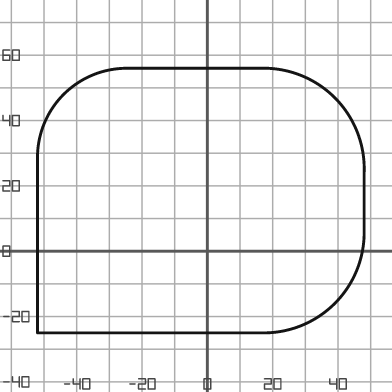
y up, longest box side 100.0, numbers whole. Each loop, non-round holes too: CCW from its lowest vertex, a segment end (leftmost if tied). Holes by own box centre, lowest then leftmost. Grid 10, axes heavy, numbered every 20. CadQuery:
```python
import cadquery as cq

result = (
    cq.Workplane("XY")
    .moveTo(-52.0, -25.0)
    .lineTo(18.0, -25.0)
    .threePointArc((39.0, -16.0), (48.0, 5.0))
    .lineTo(48.0, 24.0)
    .threePointArc((39.0, 47.0), (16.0, 56.0))
    .lineTo(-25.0, 56.0)
    .threePointArc((-44.0, 48.0), (-52.0, 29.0))
    .close()
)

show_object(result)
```